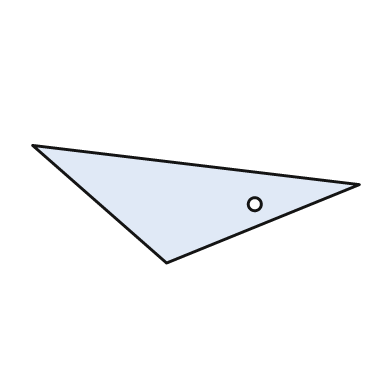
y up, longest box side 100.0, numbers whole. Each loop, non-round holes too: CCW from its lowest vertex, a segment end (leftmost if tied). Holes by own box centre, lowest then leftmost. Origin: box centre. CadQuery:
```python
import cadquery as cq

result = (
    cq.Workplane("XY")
    .moveTo(-9.0, -18.0)
    .lineTo(50.0, 6.0)
    .lineTo(-50.0, 18.0)
    .close()
    .moveTo(18.0, 0.0)
    .circle(2.0)
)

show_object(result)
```